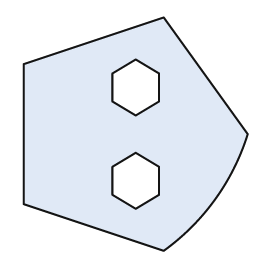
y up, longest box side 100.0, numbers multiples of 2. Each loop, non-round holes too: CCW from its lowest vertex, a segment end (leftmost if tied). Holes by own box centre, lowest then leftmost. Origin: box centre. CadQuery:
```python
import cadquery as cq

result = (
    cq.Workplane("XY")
    .moveTo(12.0, -50.0)
    .threePointArc((34.0, -28.0), (48.0, 0.0))
    .lineTo(12.0, 50.0)
    .lineTo(-48.0, 30.0)
    .lineTo(-48.0, -30.0)
    .close()
    .moveTo(0.0, -32.0)
    .lineTo(10.0, -26.0)
    .lineTo(10.0, -14.0)
    .lineTo(0.0, -8.0)
    .lineTo(-10.0, -14.0)
    .lineTo(-10.0, -26.0)
    .close()
    .moveTo(0.0, 8.0)
    .lineTo(10.0, 14.0)
    .lineTo(10.0, 26.0)
    .lineTo(0.0, 32.0)
    .lineTo(-10.0, 26.0)
    .lineTo(-10.0, 14.0)
    .close()
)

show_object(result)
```